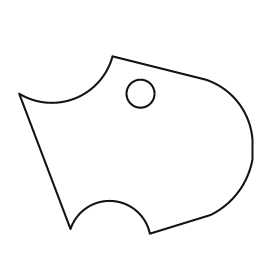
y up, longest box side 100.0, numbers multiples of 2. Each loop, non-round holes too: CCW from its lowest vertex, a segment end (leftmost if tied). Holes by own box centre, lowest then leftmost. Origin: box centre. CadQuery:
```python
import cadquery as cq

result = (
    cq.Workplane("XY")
    .moveTo(6.0, -38.0)
    .lineTo(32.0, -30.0)
    .threePointArc((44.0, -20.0), (50.0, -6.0))
    .lineTo(50.0, 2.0)
    .threePointArc((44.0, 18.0), (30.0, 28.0))
    .lineTo(-10.0, 38.0)
    .threePointArc((-26.0, 20.0), (-50.0, 22.0))
    .lineTo(-28.0, -36.0)
    .threePointArc((-10.0, -24.0), (6.0, -38.0))
    .close()
    .moveTo(2.0, 22.0)
    .circle(6.0)
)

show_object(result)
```